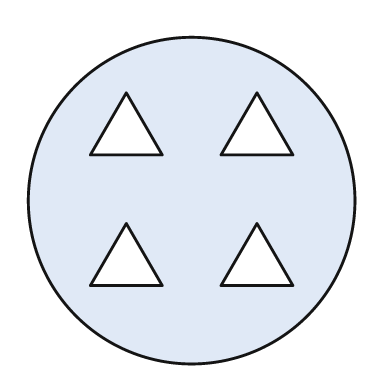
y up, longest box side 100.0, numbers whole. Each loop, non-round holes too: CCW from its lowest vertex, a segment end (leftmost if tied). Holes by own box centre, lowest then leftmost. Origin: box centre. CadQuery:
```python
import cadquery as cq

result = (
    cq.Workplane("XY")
    .moveTo(0.0, 0.0)
    .circle(50.0)
    .moveTo(-31.0, -26.0)
    .lineTo(-9.0, -26.0)
    .lineTo(-20.0, -7.0)
    .close()
    .moveTo(9.0, -26.0)
    .lineTo(31.0, -26.0)
    .lineTo(20.0, -7.0)
    .close()
    .moveTo(-31.0, 14.0)
    .lineTo(-9.0, 14.0)
    .lineTo(-20.0, 33.0)
    .close()
    .moveTo(9.0, 14.0)
    .lineTo(31.0, 14.0)
    .lineTo(20.0, 33.0)
    .close()
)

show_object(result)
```